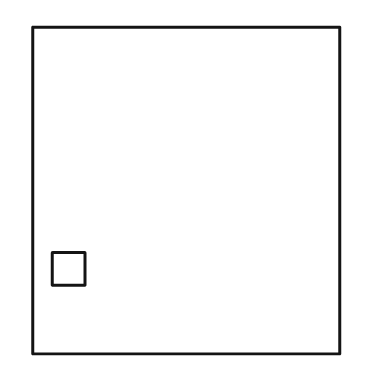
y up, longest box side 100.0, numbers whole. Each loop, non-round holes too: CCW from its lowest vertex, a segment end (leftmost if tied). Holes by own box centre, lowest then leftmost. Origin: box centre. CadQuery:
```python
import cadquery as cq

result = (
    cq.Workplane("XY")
    .moveTo(-47.0, -50.0)
    .lineTo(47.0, -50.0)
    .lineTo(47.0, 50.0)
    .lineTo(-47.0, 50.0)
    .close()
    .moveTo(-41.0, -29.0)
    .lineTo(-31.0, -29.0)
    .lineTo(-31.0, -19.0)
    .lineTo(-41.0, -19.0)
    .close()
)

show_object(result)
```